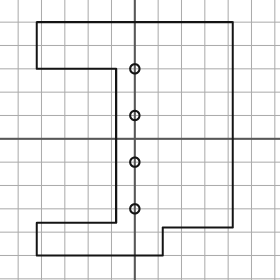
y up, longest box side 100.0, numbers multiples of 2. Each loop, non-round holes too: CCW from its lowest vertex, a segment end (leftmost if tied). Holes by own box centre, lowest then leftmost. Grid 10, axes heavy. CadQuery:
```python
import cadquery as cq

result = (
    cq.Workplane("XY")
    .moveTo(-42.0, -50.0)
    .lineTo(12.0, -50.0)
    .lineTo(12.0, -38.0)
    .lineTo(42.0, -38.0)
    .lineTo(42.0, 50.0)
    .lineTo(-42.0, 50.0)
    .lineTo(-42.0, 30.0)
    .lineTo(-8.0, 30.0)
    .lineTo(-8.0, -36.0)
    .lineTo(-42.0, -36.0)
    .close()
    .moveTo(0.0, -30.0)
    .circle(2.0)
    .moveTo(0.0, -10.0)
    .circle(2.0)
    .moveTo(0.0, 10.0)
    .circle(2.0)
    .moveTo(0.0, 30.0)
    .circle(2.0)
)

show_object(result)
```